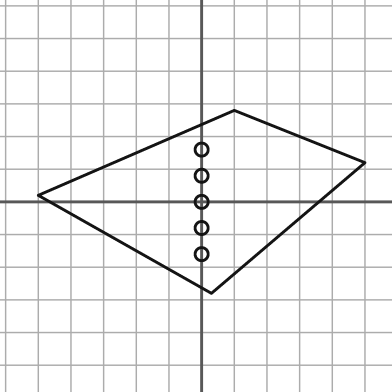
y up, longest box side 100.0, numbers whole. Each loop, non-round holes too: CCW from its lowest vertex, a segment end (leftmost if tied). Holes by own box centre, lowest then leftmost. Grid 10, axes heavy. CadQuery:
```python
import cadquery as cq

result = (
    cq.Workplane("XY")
    .moveTo(3.0, -28.0)
    .lineTo(50.0, 12.0)
    .lineTo(10.0, 28.0)
    .lineTo(-50.0, 2.0)
    .close()
    .moveTo(0.0, -16.0)
    .circle(2.0)
    .moveTo(0.0, -8.0)
    .circle(2.0)
    .moveTo(0.0, 0.0)
    .circle(2.0)
    .moveTo(0.0, 8.0)
    .circle(2.0)
    .moveTo(0.0, 16.0)
    .circle(2.0)
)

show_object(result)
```